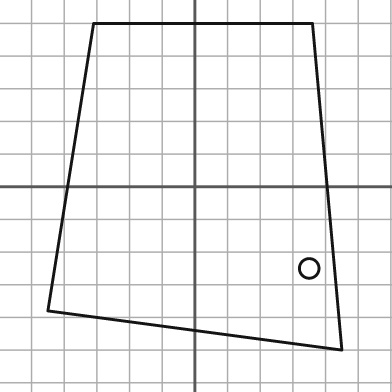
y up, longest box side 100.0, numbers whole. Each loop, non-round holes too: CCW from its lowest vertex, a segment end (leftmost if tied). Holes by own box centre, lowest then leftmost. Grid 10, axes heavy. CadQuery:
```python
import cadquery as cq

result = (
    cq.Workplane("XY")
    .moveTo(45.0, -50.0)
    .lineTo(36.0, 50.0)
    .lineTo(-31.0, 50.0)
    .lineTo(-45.0, -38.0)
    .close()
    .moveTo(35.0, -25.0)
    .circle(3.0)
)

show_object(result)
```